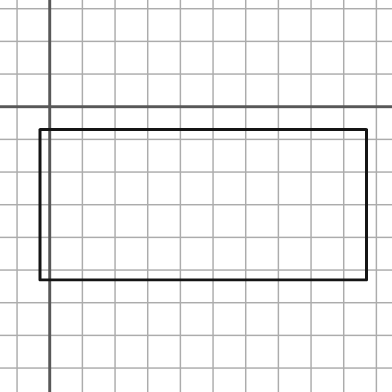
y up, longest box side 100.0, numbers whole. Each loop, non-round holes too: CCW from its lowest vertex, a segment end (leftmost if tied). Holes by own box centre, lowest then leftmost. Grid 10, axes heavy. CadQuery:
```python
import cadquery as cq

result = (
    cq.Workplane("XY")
    .moveTo(-3.0, -53.0)
    .lineTo(97.0, -53.0)
    .lineTo(97.0, -7.0)
    .lineTo(-3.0, -7.0)
    .close()
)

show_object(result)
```